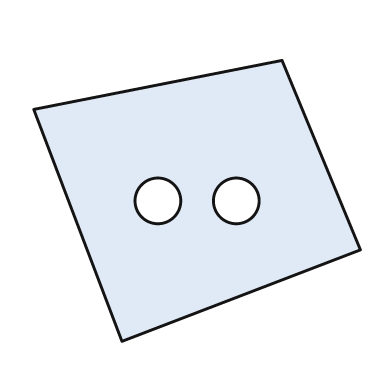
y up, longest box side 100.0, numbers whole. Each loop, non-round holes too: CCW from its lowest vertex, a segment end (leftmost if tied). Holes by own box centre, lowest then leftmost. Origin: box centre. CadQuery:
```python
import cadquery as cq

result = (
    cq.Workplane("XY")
    .moveTo(-23.0, -43.0)
    .lineTo(50.0, -15.0)
    .lineTo(26.0, 43.0)
    .lineTo(-50.0, 28.0)
    .close()
    .moveTo(-12.0, 0.0)
    .circle(7.0)
    .moveTo(12.0, 0.0)
    .circle(7.0)
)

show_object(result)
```